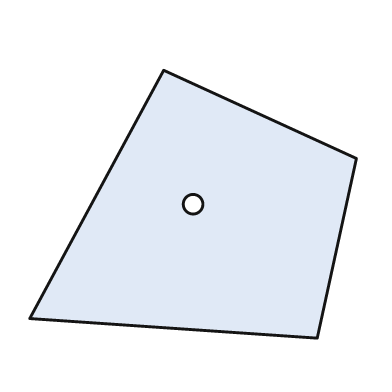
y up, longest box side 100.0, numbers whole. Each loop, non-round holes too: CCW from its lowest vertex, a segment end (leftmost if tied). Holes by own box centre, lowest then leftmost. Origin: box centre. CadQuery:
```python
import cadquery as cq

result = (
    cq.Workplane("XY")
    .moveTo(38.0, -41.0)
    .lineTo(50.0, 14.0)
    .lineTo(-9.0, 41.0)
    .lineTo(-50.0, -35.0)
    .close()
    .moveTo(0.0, 0.0)
    .circle(3.0)
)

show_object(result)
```